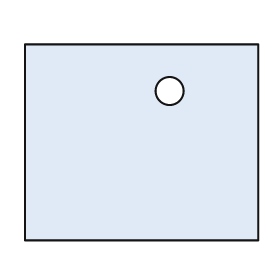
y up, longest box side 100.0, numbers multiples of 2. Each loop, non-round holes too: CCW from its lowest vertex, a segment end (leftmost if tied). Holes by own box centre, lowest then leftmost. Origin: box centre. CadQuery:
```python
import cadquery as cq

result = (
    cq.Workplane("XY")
    .moveTo(-50.0, -42.0)
    .lineTo(50.0, -42.0)
    .lineTo(50.0, 42.0)
    .lineTo(-50.0, 42.0)
    .close()
    .moveTo(12.0, 22.0)
    .circle(6.0)
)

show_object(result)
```